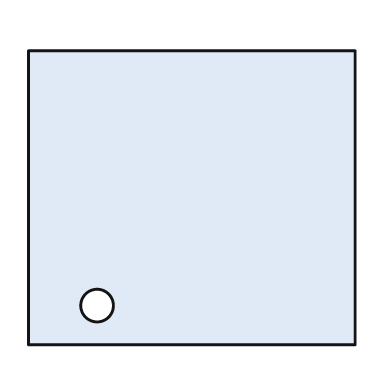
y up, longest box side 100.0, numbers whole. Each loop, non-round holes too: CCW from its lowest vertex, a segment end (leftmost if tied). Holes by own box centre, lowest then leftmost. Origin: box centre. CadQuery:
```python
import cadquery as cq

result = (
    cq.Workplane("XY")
    .moveTo(-50.0, -45.0)
    .lineTo(50.0, -45.0)
    .lineTo(50.0, 45.0)
    .lineTo(-50.0, 45.0)
    .close()
    .moveTo(-29.0, -33.0)
    .circle(5.0)
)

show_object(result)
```